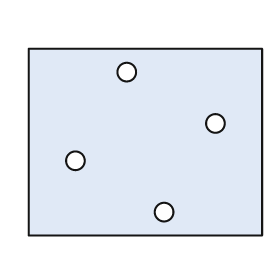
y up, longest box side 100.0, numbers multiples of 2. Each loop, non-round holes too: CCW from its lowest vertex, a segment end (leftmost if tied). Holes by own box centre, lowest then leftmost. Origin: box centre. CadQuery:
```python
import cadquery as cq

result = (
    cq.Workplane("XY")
    .moveTo(-50.0, -40.0)
    .lineTo(50.0, -40.0)
    .lineTo(50.0, 40.0)
    .lineTo(-50.0, 40.0)
    .close()
    .moveTo(8.0, -30.0)
    .circle(4.0)
    .moveTo(-30.0, -8.0)
    .circle(4.0)
    .moveTo(30.0, 8.0)
    .circle(4.0)
    .moveTo(-8.0, 30.0)
    .circle(4.0)
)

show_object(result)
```